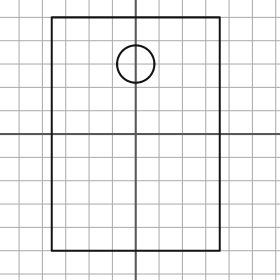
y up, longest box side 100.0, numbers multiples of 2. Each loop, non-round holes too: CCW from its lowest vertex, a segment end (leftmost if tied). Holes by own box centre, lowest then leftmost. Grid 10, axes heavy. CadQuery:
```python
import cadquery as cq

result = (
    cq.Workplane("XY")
    .moveTo(-36.0, -50.0)
    .lineTo(36.0, -50.0)
    .lineTo(36.0, 50.0)
    .lineTo(-36.0, 50.0)
    .close()
    .moveTo(0.0, 30.0)
    .circle(8.0)
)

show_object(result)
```